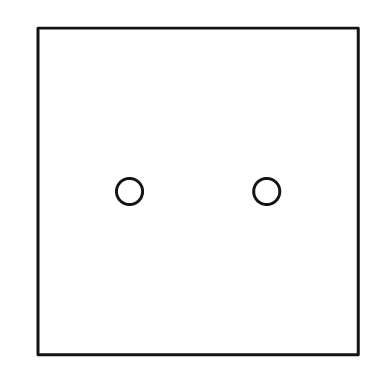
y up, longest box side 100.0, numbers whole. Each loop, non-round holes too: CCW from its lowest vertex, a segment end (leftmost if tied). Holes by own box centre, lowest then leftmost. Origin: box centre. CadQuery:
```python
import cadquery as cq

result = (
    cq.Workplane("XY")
    .moveTo(-49.0, -50.0)
    .lineTo(49.0, -50.0)
    .lineTo(49.0, 50.0)
    .lineTo(-49.0, 50.0)
    .close()
    .moveTo(-21.0, 0.0)
    .circle(4.0)
    .moveTo(21.0, 0.0)
    .circle(4.0)
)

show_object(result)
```